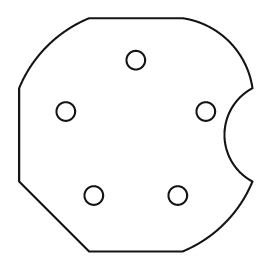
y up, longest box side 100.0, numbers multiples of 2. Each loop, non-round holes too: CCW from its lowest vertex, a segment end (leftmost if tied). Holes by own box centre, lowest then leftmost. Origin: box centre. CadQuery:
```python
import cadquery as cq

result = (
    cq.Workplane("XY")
    .moveTo(-20.0, -50.0)
    .lineTo(20.0, -50.0)
    .threePointArc((38.0, -38.0), (50.0, -20.0))
    .threePointArc((38.0, 0.0), (50.0, 20.0))
    .threePointArc((40.0, 40.0), (20.0, 50.0))
    .lineTo(-20.0, 50.0)
    .threePointArc((-38.0, 38.0), (-50.0, 20.0))
    .lineTo(-50.0, -20.0)
    .close()
    .moveTo(-18.0, -26.0)
    .circle(4.0)
    .moveTo(18.0, -26.0)
    .circle(4.0)
    .moveTo(-30.0, 10.0)
    .circle(4.0)
    .moveTo(30.0, 10.0)
    .circle(4.0)
    .moveTo(0.0, 32.0)
    .circle(4.0)
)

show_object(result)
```